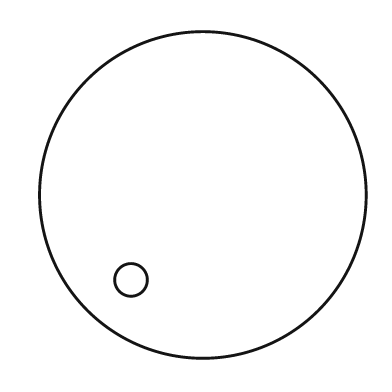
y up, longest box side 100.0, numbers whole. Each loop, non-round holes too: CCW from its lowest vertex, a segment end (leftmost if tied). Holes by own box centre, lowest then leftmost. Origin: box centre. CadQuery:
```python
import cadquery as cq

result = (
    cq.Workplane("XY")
    .moveTo(0.0, 0.0)
    .circle(50.0)
    .moveTo(-22.0, -26.0)
    .circle(5.0)
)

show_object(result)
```